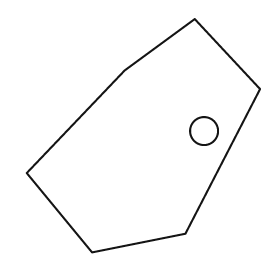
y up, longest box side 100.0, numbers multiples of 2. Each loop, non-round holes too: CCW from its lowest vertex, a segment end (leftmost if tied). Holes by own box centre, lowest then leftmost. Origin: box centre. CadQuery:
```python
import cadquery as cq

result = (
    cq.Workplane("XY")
    .moveTo(-22.0, -50.0)
    .lineTo(18.0, -42.0)
    .lineTo(50.0, 20.0)
    .lineTo(22.0, 50.0)
    .lineTo(-8.0, 28.0)
    .lineTo(-50.0, -16.0)
    .close()
    .moveTo(26.0, 2.0)
    .circle(6.0)
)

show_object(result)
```